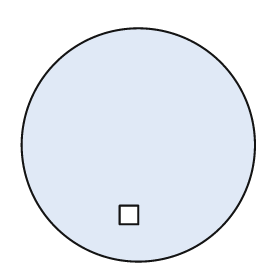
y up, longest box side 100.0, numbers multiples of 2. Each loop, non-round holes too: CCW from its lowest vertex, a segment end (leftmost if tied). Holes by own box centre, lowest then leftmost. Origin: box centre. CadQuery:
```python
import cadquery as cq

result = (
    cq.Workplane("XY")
    .moveTo(0.0, 0.0)
    .circle(50.0)
    .moveTo(-8.0, -34.0)
    .lineTo(0.0, -34.0)
    .lineTo(0.0, -26.0)
    .lineTo(-8.0, -26.0)
    .close()
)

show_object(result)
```